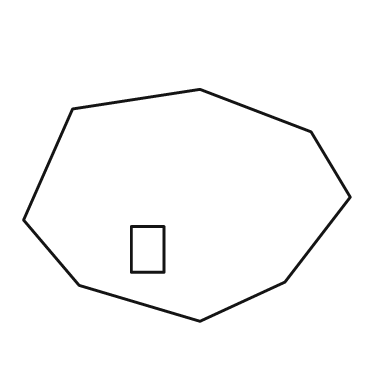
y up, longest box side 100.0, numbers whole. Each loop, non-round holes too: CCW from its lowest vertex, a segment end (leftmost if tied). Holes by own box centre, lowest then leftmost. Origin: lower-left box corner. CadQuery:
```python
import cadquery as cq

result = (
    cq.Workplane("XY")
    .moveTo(54.0, 0.0)
    .lineTo(80.0, 12.0)
    .lineTo(100.0, 38.0)
    .lineTo(88.0, 58.0)
    .lineTo(54.0, 71.0)
    .lineTo(15.0, 65.0)
    .lineTo(0.0, 31.0)
    .lineTo(17.0, 11.0)
    .close()
    .moveTo(33.0, 15.0)
    .lineTo(43.0, 15.0)
    .lineTo(43.0, 29.0)
    .lineTo(33.0, 29.0)
    .close()
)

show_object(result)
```